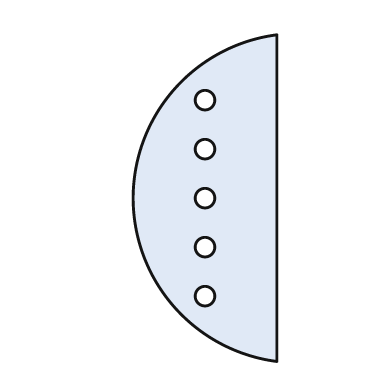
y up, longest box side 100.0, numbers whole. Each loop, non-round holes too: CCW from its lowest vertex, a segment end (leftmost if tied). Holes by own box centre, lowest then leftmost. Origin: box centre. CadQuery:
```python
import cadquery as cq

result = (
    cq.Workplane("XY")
    .moveTo(22.0, -50.0)
    .lineTo(22.0, 50.0)
    .threePointArc((-22.0, 0.0), (22.0, -50.0))
    .close()
    .moveTo(0.0, -30.0)
    .circle(3.0)
    .moveTo(0.0, -15.0)
    .circle(3.0)
    .moveTo(0.0, 0.0)
    .circle(3.0)
    .moveTo(0.0, 15.0)
    .circle(3.0)
    .moveTo(0.0, 30.0)
    .circle(3.0)
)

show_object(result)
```